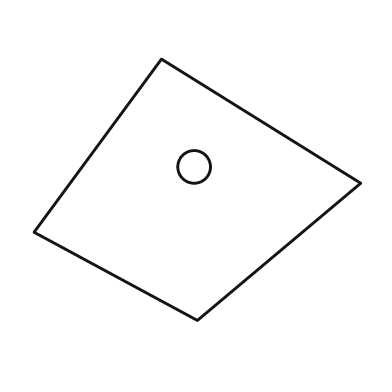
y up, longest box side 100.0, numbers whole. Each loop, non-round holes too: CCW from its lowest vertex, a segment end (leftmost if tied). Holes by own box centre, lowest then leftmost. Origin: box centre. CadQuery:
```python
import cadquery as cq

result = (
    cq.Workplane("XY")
    .moveTo(0.0, -40.0)
    .lineTo(50.0, 2.0)
    .lineTo(-11.0, 40.0)
    .lineTo(-50.0, -13.0)
    .close()
    .moveTo(-1.0, 7.0)
    .circle(5.0)
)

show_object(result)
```